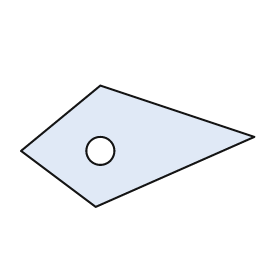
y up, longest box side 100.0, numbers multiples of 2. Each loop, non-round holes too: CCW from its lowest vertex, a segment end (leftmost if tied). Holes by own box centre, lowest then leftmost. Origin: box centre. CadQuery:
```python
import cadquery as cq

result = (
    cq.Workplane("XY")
    .moveTo(-18.0, -26.0)
    .lineTo(50.0, 4.0)
    .lineTo(-16.0, 26.0)
    .lineTo(-50.0, -2.0)
    .close()
    .moveTo(-16.0, -2.0)
    .circle(6.0)
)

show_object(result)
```